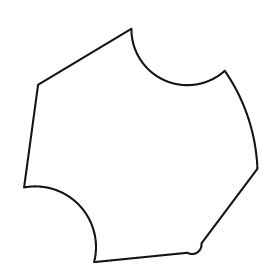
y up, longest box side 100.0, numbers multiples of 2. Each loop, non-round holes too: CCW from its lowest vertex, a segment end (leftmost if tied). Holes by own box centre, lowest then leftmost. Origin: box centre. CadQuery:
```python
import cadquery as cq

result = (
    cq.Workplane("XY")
    .moveTo(-20.0, -50.0)
    .lineTo(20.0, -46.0)
    .threePointArc((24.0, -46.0), (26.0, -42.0))
    .lineTo(50.0, -10.0)
    .threePointArc((46.0, 12.0), (36.0, 32.0))
    .threePointArc((10.0, 28.0), (-4.0, 50.0))
    .lineTo(-44.0, 26.0)
    .lineTo(-50.0, -18.0)
    .threePointArc((-26.0, -26.0), (-20.0, -50.0))
    .close()
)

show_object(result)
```